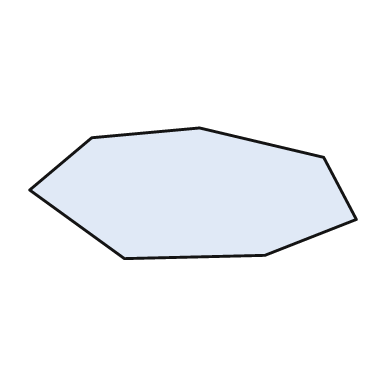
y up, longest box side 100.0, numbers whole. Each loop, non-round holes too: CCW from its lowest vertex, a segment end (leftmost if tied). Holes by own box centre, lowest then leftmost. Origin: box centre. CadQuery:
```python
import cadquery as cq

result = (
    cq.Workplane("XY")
    .moveTo(-21.0, -20.0)
    .lineTo(22.0, -19.0)
    .lineTo(50.0, -8.0)
    .lineTo(40.0, 11.0)
    .lineTo(2.0, 20.0)
    .lineTo(-31.0, 17.0)
    .lineTo(-50.0, 1.0)
    .close()
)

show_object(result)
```